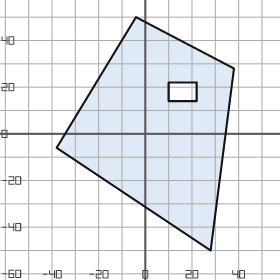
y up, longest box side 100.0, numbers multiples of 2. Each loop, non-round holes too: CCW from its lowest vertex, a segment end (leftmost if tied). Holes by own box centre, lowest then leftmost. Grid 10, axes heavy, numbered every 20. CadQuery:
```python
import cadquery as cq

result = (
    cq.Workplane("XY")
    .moveTo(28.0, -50.0)
    .lineTo(38.0, 28.0)
    .lineTo(-4.0, 50.0)
    .lineTo(-38.0, -6.0)
    .close()
    .moveTo(10.0, 14.0)
    .lineTo(22.0, 14.0)
    .lineTo(22.0, 22.0)
    .lineTo(10.0, 22.0)
    .close()
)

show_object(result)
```